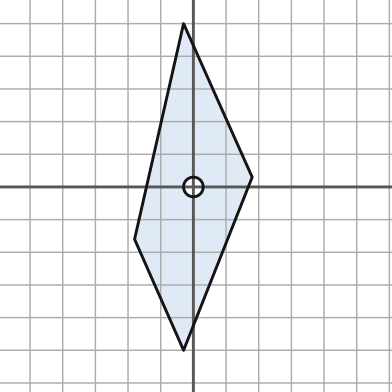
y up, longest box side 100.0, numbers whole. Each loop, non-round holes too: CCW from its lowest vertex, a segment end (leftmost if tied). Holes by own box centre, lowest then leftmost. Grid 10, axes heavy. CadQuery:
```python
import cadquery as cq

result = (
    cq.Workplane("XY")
    .moveTo(-3.0, -50.0)
    .lineTo(18.0, 3.0)
    .lineTo(-3.0, 50.0)
    .lineTo(-18.0, -16.0)
    .close()
    .moveTo(0.0, 0.0)
    .circle(3.0)
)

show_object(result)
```